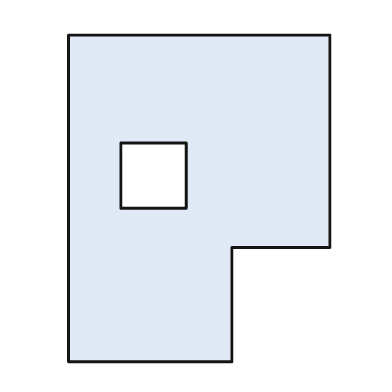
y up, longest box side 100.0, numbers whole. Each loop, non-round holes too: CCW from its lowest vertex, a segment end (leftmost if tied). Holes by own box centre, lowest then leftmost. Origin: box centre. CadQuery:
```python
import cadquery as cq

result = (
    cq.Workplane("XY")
    .moveTo(-40.0, -50.0)
    .lineTo(10.0, -50.0)
    .lineTo(10.0, -15.0)
    .lineTo(40.0, -15.0)
    .lineTo(40.0, 50.0)
    .lineTo(-40.0, 50.0)
    .close()
    .moveTo(-24.0, -3.0)
    .lineTo(-4.0, -3.0)
    .lineTo(-4.0, 17.0)
    .lineTo(-24.0, 17.0)
    .close()
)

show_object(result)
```